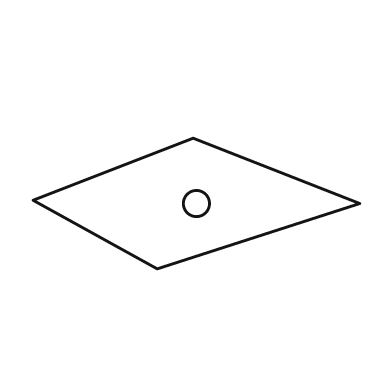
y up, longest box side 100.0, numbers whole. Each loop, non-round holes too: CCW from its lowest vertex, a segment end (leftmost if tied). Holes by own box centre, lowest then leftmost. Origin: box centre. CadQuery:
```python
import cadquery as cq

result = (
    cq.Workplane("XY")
    .moveTo(-12.0, -20.0)
    .lineTo(50.0, 0.0)
    .lineTo(-1.0, 20.0)
    .lineTo(-50.0, 1.0)
    .close()
    .moveTo(0.0, 0.0)
    .circle(4.0)
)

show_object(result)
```